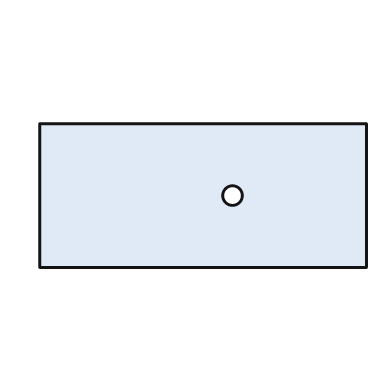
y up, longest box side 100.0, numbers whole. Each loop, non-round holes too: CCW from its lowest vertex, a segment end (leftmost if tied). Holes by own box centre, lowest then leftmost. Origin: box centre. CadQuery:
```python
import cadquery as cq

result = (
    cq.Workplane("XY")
    .moveTo(-50.0, -22.0)
    .lineTo(50.0, -22.0)
    .lineTo(50.0, 22.0)
    .lineTo(-50.0, 22.0)
    .close()
    .moveTo(9.0, 0.0)
    .circle(3.0)
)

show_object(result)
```